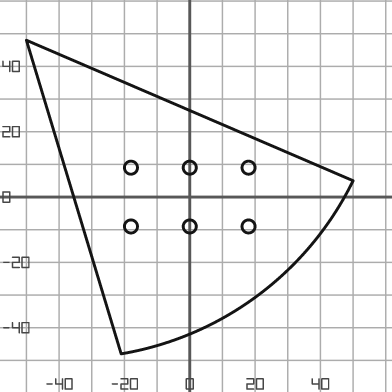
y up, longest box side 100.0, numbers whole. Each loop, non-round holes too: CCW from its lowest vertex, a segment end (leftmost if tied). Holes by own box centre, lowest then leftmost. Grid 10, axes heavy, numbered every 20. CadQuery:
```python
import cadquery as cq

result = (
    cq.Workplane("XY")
    .moveTo(-21.0, -48.0)
    .threePointArc((21.0, -30.0), (50.0, 5.0))
    .lineTo(-50.0, 48.0)
    .close()
    .moveTo(-18.0, -9.0)
    .circle(2.0)
    .moveTo(0.0, -9.0)
    .circle(2.0)
    .moveTo(18.0, -9.0)
    .circle(2.0)
    .moveTo(-18.0, 9.0)
    .circle(2.0)
    .moveTo(0.0, 9.0)
    .circle(2.0)
    .moveTo(18.0, 9.0)
    .circle(2.0)
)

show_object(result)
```